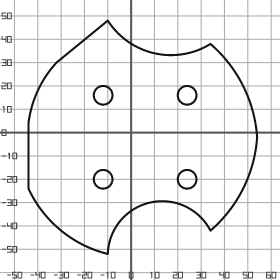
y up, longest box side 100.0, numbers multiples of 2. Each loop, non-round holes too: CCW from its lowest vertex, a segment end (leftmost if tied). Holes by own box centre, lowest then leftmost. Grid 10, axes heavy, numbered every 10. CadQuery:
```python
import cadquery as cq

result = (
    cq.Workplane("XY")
    .moveTo(-10.0, -52.0)
    .threePointArc((8.0, -30.0), (34.0, -42.0))
    .threePointArc((48.0, -24.0), (54.0, -2.0))
    .threePointArc((48.0, 20.0), (34.0, 38.0))
    .threePointArc((10.0, 34.0), (-10.0, 48.0))
    .lineTo(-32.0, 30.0)
    .threePointArc((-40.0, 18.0), (-44.0, 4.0))
    .lineTo(-44.0, -24.0)
    .threePointArc((-30.0, -42.0), (-10.0, -52.0))
    .close()
    .moveTo(-12.0, -20.0)
    .circle(4.0)
    .moveTo(24.0, -20.0)
    .circle(4.0)
    .moveTo(-12.0, 16.0)
    .circle(4.0)
    .moveTo(24.0, 16.0)
    .circle(4.0)
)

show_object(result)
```